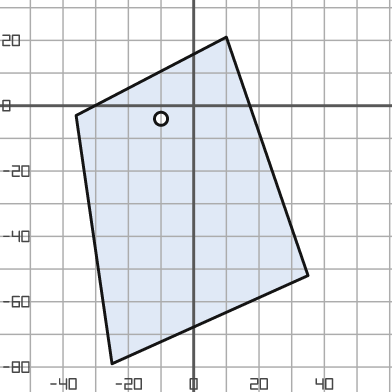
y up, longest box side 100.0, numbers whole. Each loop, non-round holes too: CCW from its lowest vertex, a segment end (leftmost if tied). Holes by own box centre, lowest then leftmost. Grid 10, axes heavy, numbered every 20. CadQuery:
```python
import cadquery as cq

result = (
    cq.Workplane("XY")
    .moveTo(-25.0, -79.0)
    .lineTo(35.0, -52.0)
    .lineTo(10.0, 21.0)
    .lineTo(-36.0, -3.0)
    .close()
    .moveTo(-10.0, -4.0)
    .circle(2.0)
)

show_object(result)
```